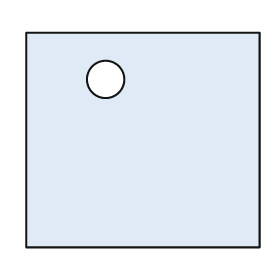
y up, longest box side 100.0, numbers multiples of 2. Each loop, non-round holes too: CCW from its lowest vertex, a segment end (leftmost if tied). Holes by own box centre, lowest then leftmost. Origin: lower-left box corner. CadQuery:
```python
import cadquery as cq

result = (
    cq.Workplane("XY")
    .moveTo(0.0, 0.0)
    .lineTo(100.0, 0.0)
    .lineTo(100.0, 92.0)
    .lineTo(0.0, 92.0)
    .close()
    .moveTo(34.0, 72.0)
    .circle(8.0)
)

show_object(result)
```